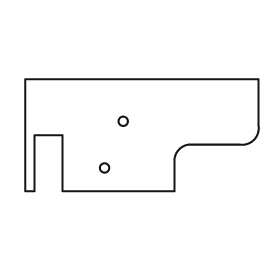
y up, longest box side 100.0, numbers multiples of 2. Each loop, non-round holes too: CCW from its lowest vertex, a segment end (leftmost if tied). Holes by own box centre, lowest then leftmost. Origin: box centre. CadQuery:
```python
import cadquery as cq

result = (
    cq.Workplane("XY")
    .moveTo(-50.0, -24.0)
    .lineTo(-46.0, -24.0)
    .lineTo(-46.0, 0.0)
    .lineTo(-34.0, 0.0)
    .lineTo(-34.0, -24.0)
    .lineTo(14.0, -24.0)
    .lineTo(14.0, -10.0)
    .threePointArc((16.0, -6.0), (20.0, -4.0))
    .lineTo(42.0, -4.0)
    .threePointArc((48.0, -2.0), (50.0, 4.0))
    .lineTo(50.0, 24.0)
    .lineTo(-50.0, 24.0)
    .close()
    .moveTo(-16.0, -14.0)
    .circle(2.0)
    .moveTo(-8.0, 6.0)
    .circle(2.0)
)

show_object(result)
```